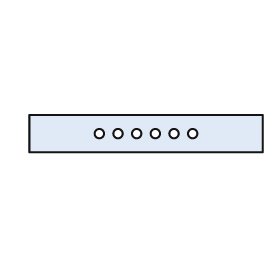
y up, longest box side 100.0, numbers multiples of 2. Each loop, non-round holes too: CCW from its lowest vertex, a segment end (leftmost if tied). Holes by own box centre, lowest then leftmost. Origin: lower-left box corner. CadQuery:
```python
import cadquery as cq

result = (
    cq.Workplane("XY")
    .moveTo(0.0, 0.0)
    .lineTo(100.0, 0.0)
    .lineTo(100.0, 16.0)
    .lineTo(0.0, 16.0)
    .close()
    .moveTo(30.0, 8.0)
    .circle(2.0)
    .moveTo(38.0, 8.0)
    .circle(2.0)
    .moveTo(46.0, 8.0)
    .circle(2.0)
    .moveTo(54.0, 8.0)
    .circle(2.0)
    .moveTo(62.0, 8.0)
    .circle(2.0)
    .moveTo(70.0, 8.0)
    .circle(2.0)
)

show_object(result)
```